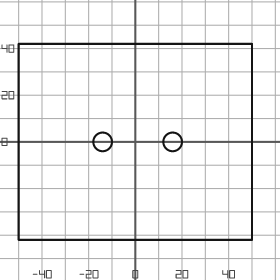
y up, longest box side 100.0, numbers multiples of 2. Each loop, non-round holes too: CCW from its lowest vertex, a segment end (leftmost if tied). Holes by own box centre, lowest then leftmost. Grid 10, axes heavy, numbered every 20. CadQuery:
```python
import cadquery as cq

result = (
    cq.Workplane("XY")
    .moveTo(-50.0, -42.0)
    .lineTo(50.0, -42.0)
    .lineTo(50.0, 42.0)
    .lineTo(-50.0, 42.0)
    .close()
    .moveTo(-14.0, 0.0)
    .circle(4.0)
    .moveTo(16.0, 0.0)
    .circle(4.0)
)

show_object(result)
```